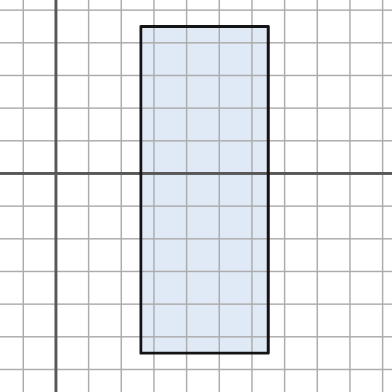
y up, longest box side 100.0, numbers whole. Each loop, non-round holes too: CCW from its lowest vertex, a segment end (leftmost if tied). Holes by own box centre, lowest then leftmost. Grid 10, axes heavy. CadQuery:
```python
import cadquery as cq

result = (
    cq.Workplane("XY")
    .moveTo(26.0, -55.0)
    .lineTo(65.0, -55.0)
    .lineTo(65.0, 45.0)
    .lineTo(26.0, 45.0)
    .close()
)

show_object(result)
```